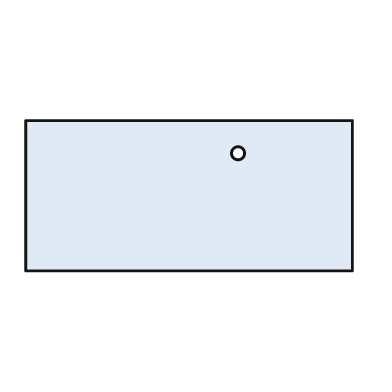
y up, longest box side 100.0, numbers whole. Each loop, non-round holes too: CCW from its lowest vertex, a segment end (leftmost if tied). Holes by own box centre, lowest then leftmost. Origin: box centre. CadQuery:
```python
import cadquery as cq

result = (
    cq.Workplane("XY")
    .moveTo(-50.0, -23.0)
    .lineTo(50.0, -23.0)
    .lineTo(50.0, 23.0)
    .lineTo(-50.0, 23.0)
    .close()
    .moveTo(15.0, 13.0)
    .circle(2.0)
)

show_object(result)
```